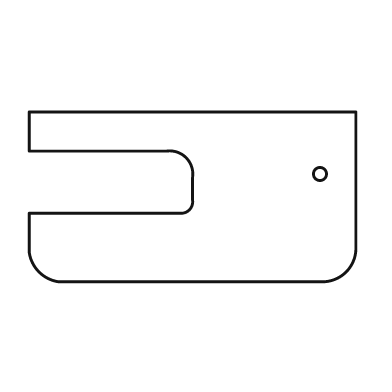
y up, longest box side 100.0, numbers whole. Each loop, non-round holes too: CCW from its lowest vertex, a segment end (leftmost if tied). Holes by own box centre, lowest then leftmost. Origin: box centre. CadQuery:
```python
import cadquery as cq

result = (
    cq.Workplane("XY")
    .moveTo(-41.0, -26.0)
    .lineTo(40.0, -26.0)
    .threePointArc((47.0, -23.0), (50.0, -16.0))
    .lineTo(50.0, 26.0)
    .lineTo(-50.0, 26.0)
    .lineTo(-50.0, 14.0)
    .lineTo(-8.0, 14.0)
    .threePointArc((-2.0, 12.0), (0.0, 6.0))
    .lineTo(0.0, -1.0)
    .threePointArc((-1.0, -4.0), (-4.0, -5.0))
    .lineTo(-50.0, -5.0)
    .lineTo(-50.0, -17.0)
    .threePointArc((-47.0, -23.0), (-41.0, -26.0))
    .close()
    .moveTo(39.0, 7.0)
    .circle(2.0)
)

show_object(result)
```